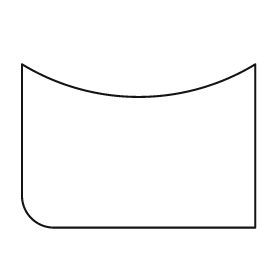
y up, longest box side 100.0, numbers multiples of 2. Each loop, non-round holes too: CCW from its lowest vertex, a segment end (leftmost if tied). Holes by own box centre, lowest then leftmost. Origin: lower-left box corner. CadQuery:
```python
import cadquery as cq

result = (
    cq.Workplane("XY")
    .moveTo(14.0, 0.0)
    .lineTo(100.0, 0.0)
    .lineTo(100.0, 70.0)
    .threePointArc((50.0, 56.0), (0.0, 70.0))
    .lineTo(0.0, 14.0)
    .threePointArc((4.0, 4.0), (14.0, 0.0))
    .close()
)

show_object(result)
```